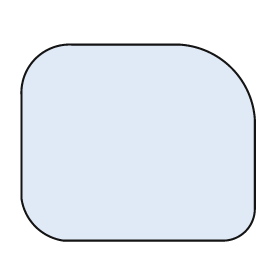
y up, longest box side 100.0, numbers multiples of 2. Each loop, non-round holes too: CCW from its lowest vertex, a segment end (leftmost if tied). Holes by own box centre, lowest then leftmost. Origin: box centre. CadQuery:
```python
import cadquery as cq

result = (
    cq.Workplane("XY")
    .moveTo(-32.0, -42.0)
    .lineTo(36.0, -42.0)
    .threePointArc((46.0, -38.0), (50.0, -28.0))
    .lineTo(50.0, 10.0)
    .threePointArc((40.0, 32.0), (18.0, 42.0))
    .lineTo(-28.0, 42.0)
    .threePointArc((-44.0, 36.0), (-50.0, 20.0))
    .lineTo(-50.0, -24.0)
    .threePointArc((-44.0, -36.0), (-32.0, -42.0))
    .close()
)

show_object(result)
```